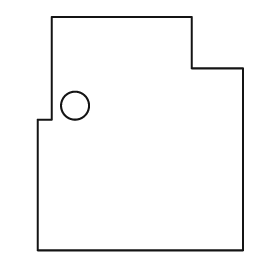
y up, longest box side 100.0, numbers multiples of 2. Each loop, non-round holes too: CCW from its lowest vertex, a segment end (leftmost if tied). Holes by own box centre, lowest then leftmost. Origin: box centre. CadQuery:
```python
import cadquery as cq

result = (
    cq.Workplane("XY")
    .moveTo(-44.0, -50.0)
    .lineTo(44.0, -50.0)
    .lineTo(44.0, 28.0)
    .lineTo(22.0, 28.0)
    .lineTo(22.0, 50.0)
    .lineTo(-38.0, 50.0)
    .lineTo(-38.0, 6.0)
    .lineTo(-44.0, 6.0)
    .close()
    .moveTo(-28.0, 12.0)
    .circle(6.0)
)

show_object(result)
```